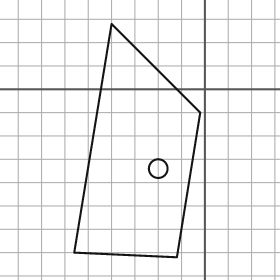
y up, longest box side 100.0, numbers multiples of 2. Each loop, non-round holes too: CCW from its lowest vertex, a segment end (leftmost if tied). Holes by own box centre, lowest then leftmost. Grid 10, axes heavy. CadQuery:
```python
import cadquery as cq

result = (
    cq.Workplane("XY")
    .moveTo(-12.0, -72.0)
    .lineTo(-2.0, -10.0)
    .lineTo(-40.0, 28.0)
    .lineTo(-56.0, -70.0)
    .close()
    .moveTo(-20.0, -34.0)
    .circle(4.0)
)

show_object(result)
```